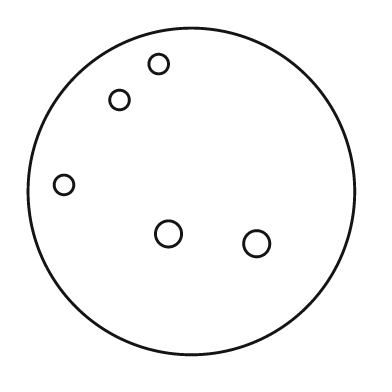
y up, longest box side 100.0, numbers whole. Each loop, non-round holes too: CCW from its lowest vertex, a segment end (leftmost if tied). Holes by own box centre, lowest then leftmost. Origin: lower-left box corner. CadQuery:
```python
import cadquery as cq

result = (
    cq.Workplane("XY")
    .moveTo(50.0, 50.0)
    .circle(50.0)
    .moveTo(70.0, 34.0)
    .circle(4.0)
    .moveTo(43.0, 37.0)
    .circle(4.0)
    .moveTo(11.0, 52.0)
    .circle(3.0)
    .moveTo(28.0, 78.0)
    .circle(3.0)
    .moveTo(40.0, 89.0)
    .circle(3.0)
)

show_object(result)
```